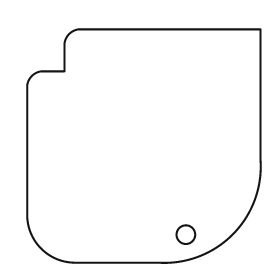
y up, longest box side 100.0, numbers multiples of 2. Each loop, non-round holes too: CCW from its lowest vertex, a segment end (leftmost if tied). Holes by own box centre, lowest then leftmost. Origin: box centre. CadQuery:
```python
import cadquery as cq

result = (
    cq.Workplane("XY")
    .moveTo(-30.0, -50.0)
    .lineTo(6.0, -50.0)
    .threePointArc((38.0, -38.0), (50.0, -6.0))
    .lineTo(50.0, 50.0)
    .lineTo(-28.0, 50.0)
    .threePointArc((-32.0, 48.0), (-34.0, 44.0))
    .lineTo(-34.0, 32.0)
    .lineTo(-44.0, 32.0)
    .threePointArc((-48.0, 30.0), (-50.0, 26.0))
    .lineTo(-50.0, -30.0)
    .threePointArc((-44.0, -44.0), (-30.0, -50.0))
    .close()
    .moveTo(18.0, -38.0)
    .circle(4.0)
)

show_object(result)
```